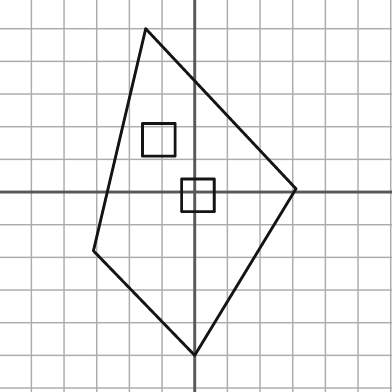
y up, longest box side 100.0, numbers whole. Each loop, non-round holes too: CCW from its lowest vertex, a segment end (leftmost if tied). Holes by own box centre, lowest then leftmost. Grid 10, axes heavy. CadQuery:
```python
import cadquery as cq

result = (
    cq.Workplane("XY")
    .moveTo(0.0, -50.0)
    .lineTo(31.0, 1.0)
    .lineTo(-15.0, 50.0)
    .lineTo(-31.0, -18.0)
    .close()
    .moveTo(-4.0, -6.0)
    .lineTo(6.0, -6.0)
    .lineTo(6.0, 4.0)
    .lineTo(-4.0, 4.0)
    .close()
    .moveTo(-16.0, 11.0)
    .lineTo(-6.0, 11.0)
    .lineTo(-6.0, 21.0)
    .lineTo(-16.0, 21.0)
    .close()
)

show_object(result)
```